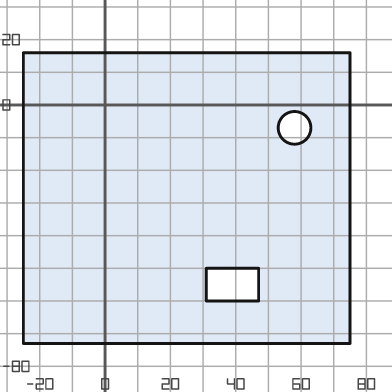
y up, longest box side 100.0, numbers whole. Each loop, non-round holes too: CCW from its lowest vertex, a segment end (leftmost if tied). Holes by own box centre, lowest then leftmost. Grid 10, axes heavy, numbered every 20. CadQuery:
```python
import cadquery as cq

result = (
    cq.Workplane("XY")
    .moveTo(-25.0, -73.0)
    .lineTo(75.0, -73.0)
    .lineTo(75.0, 16.0)
    .lineTo(-25.0, 16.0)
    .close()
    .moveTo(31.0, -60.0)
    .lineTo(47.0, -60.0)
    .lineTo(47.0, -50.0)
    .lineTo(31.0, -50.0)
    .close()
    .moveTo(58.0, -7.0)
    .circle(5.0)
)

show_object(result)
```